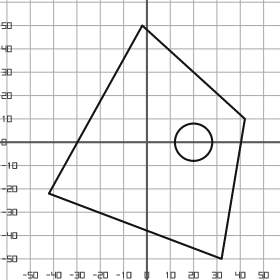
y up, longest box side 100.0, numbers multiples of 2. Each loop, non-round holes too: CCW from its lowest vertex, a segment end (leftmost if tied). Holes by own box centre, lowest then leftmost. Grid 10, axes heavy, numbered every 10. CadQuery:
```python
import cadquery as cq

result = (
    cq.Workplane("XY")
    .moveTo(32.0, -50.0)
    .lineTo(42.0, 10.0)
    .lineTo(-2.0, 50.0)
    .lineTo(-42.0, -22.0)
    .close()
    .moveTo(20.0, 0.0)
    .circle(8.0)
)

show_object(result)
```